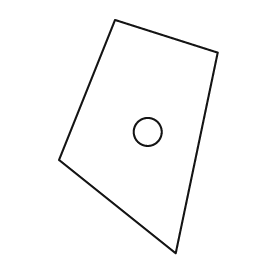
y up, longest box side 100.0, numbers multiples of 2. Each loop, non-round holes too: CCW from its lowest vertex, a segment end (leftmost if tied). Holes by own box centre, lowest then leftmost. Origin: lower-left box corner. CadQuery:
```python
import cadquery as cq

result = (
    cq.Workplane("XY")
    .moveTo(50.0, 0.0)
    .lineTo(68.0, 86.0)
    .lineTo(24.0, 100.0)
    .lineTo(0.0, 40.0)
    .close()
    .moveTo(38.0, 52.0)
    .circle(6.0)
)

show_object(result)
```